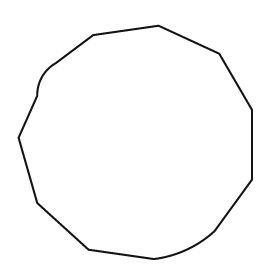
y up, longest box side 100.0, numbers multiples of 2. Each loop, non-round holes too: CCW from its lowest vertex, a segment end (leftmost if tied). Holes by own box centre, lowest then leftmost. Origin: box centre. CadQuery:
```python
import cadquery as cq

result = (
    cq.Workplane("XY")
    .moveTo(8.0, -50.0)
    .threePointArc((22.0, -46.0), (34.0, -38.0))
    .lineTo(50.0, -16.0)
    .lineTo(50.0, 14.0)
    .lineTo(36.0, 38.0)
    .lineTo(10.0, 50.0)
    .lineTo(-18.0, 46.0)
    .lineTo(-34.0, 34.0)
    .threePointArc((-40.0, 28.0), (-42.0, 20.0))
    .lineTo(-50.0, 2.0)
    .lineTo(-42.0, -26.0)
    .lineTo(-20.0, -46.0)
    .close()
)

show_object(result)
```